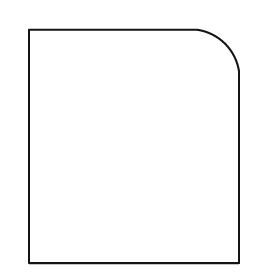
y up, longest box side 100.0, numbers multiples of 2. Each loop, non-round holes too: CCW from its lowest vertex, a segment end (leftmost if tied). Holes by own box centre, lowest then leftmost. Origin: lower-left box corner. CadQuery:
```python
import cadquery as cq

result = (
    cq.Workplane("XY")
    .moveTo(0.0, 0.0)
    .lineTo(90.0, 0.0)
    .lineTo(90.0, 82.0)
    .threePointArc((84.0, 94.0), (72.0, 100.0))
    .lineTo(0.0, 100.0)
    .close()
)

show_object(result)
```